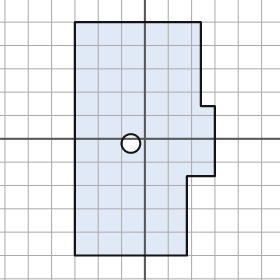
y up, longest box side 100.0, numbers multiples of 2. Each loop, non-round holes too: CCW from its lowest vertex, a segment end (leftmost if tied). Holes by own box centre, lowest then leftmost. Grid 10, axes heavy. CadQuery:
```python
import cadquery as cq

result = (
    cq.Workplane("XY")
    .moveTo(-30.0, -50.0)
    .lineTo(18.0, -50.0)
    .lineTo(18.0, -16.0)
    .lineTo(30.0, -16.0)
    .lineTo(30.0, 14.0)
    .lineTo(24.0, 14.0)
    .lineTo(24.0, 50.0)
    .lineTo(-30.0, 50.0)
    .close()
    .moveTo(-6.0, -2.0)
    .circle(4.0)
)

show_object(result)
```